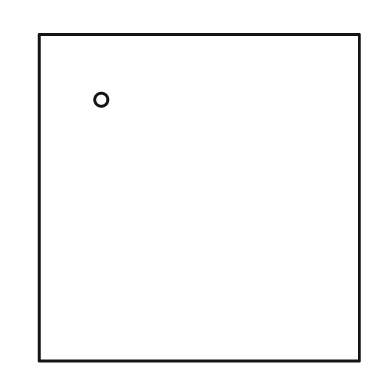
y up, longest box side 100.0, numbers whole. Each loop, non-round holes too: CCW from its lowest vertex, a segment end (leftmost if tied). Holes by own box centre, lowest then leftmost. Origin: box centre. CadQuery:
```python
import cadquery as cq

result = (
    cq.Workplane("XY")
    .moveTo(-49.0, -50.0)
    .lineTo(49.0, -50.0)
    .lineTo(49.0, 50.0)
    .lineTo(-49.0, 50.0)
    .close()
    .moveTo(-30.0, 30.0)
    .circle(2.0)
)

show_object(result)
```